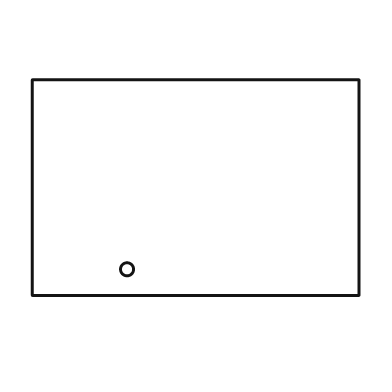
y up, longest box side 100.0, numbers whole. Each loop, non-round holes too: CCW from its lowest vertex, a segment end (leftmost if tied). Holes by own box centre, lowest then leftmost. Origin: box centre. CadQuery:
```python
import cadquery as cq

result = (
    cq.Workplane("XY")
    .moveTo(-50.0, -33.0)
    .lineTo(50.0, -33.0)
    .lineTo(50.0, 33.0)
    .lineTo(-50.0, 33.0)
    .close()
    .moveTo(-21.0, -25.0)
    .circle(2.0)
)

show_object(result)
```